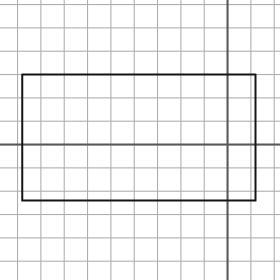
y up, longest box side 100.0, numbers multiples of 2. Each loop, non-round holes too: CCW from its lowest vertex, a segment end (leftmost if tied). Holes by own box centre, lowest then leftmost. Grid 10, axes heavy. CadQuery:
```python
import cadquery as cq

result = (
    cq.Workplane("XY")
    .moveTo(-88.0, -24.0)
    .lineTo(12.0, -24.0)
    .lineTo(12.0, 30.0)
    .lineTo(-88.0, 30.0)
    .close()
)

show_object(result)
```